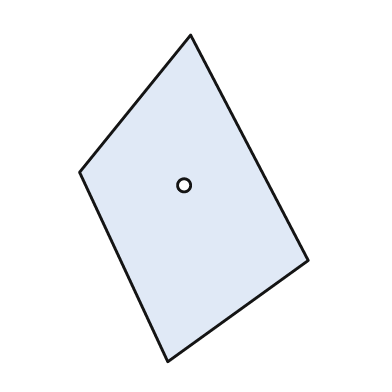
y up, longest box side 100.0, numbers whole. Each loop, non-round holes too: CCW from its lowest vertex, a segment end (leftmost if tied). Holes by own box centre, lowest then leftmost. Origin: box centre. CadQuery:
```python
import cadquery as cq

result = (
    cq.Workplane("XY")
    .moveTo(-8.0, -50.0)
    .lineTo(35.0, -19.0)
    .lineTo(-1.0, 50.0)
    .lineTo(-35.0, 8.0)
    .close()
    .moveTo(-3.0, 4.0)
    .circle(2.0)
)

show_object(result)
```